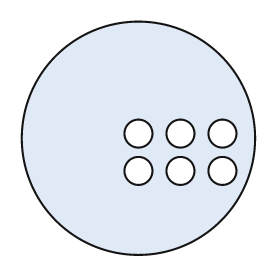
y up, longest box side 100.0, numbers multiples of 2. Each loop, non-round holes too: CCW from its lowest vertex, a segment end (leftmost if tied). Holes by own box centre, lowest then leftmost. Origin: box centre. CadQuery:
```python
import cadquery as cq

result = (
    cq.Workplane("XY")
    .moveTo(0.0, 0.0)
    .circle(50.0)
    .moveTo(0.0, -14.0)
    .circle(6.0)
    .moveTo(18.0, -14.0)
    .circle(6.0)
    .moveTo(36.0, -14.0)
    .circle(6.0)
    .moveTo(0.0, 2.0)
    .circle(6.0)
    .moveTo(18.0, 2.0)
    .circle(6.0)
    .moveTo(36.0, 2.0)
    .circle(6.0)
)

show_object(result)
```